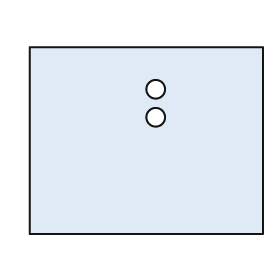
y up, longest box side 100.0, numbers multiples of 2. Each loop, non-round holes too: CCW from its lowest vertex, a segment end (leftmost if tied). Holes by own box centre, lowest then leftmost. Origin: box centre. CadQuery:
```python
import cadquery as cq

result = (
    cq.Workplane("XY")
    .moveTo(-50.0, -40.0)
    .lineTo(50.0, -40.0)
    .lineTo(50.0, 40.0)
    .lineTo(-50.0, 40.0)
    .close()
    .moveTo(4.0, 10.0)
    .circle(4.0)
    .moveTo(4.0, 22.0)
    .circle(4.0)
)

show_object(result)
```